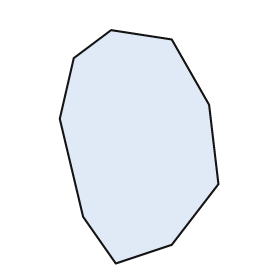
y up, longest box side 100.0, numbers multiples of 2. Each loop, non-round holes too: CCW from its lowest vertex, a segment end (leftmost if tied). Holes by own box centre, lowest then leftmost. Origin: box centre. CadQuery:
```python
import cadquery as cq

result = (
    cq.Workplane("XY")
    .moveTo(-10.0, -50.0)
    .lineTo(14.0, -42.0)
    .lineTo(34.0, -16.0)
    .lineTo(30.0, 18.0)
    .lineTo(14.0, 46.0)
    .lineTo(-12.0, 50.0)
    .lineTo(-28.0, 38.0)
    .lineTo(-34.0, 12.0)
    .lineTo(-24.0, -30.0)
    .close()
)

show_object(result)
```